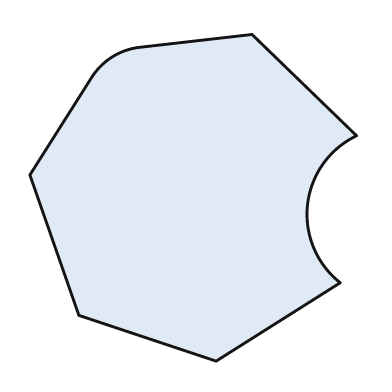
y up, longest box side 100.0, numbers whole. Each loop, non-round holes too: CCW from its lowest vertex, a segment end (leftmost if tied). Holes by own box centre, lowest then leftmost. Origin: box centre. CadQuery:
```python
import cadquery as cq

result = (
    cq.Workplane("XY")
    .moveTo(7.0, -50.0)
    .lineTo(45.0, -26.0)
    .threePointArc((35.0, -2.0), (50.0, 19.0))
    .lineTo(18.0, 50.0)
    .lineTo(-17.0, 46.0)
    .threePointArc((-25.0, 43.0), (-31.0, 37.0))
    .lineTo(-50.0, 7.0)
    .lineTo(-35.0, -36.0)
    .close()
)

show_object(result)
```